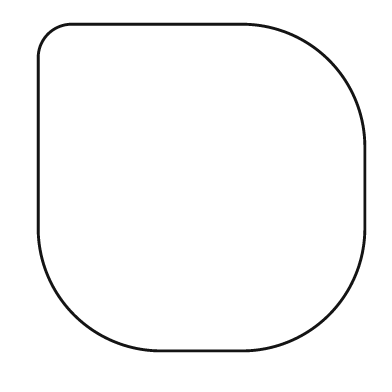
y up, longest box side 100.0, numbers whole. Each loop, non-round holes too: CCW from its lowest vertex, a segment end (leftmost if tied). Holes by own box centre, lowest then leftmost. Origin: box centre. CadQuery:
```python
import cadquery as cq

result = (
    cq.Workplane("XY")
    .moveTo(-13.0, -50.0)
    .lineTo(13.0, -50.0)
    .threePointArc((39.0, -39.0), (50.0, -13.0))
    .lineTo(50.0, 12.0)
    .threePointArc((39.0, 39.0), (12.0, 50.0))
    .lineTo(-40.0, 50.0)
    .threePointArc((-47.0, 47.0), (-50.0, 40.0))
    .lineTo(-50.0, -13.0)
    .threePointArc((-39.0, -39.0), (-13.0, -50.0))
    .close()
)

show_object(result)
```